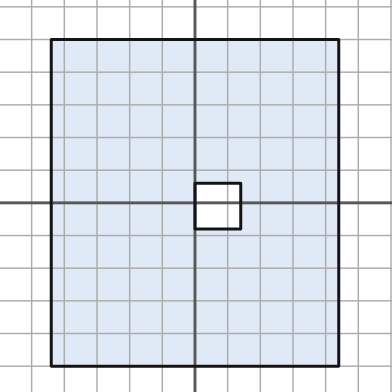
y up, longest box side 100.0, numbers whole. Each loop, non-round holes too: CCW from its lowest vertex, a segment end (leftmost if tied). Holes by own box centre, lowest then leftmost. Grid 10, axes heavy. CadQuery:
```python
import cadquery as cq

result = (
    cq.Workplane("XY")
    .moveTo(-44.0, -50.0)
    .lineTo(44.0, -50.0)
    .lineTo(44.0, 50.0)
    .lineTo(-44.0, 50.0)
    .close()
    .moveTo(0.0, -8.0)
    .lineTo(14.0, -8.0)
    .lineTo(14.0, 6.0)
    .lineTo(0.0, 6.0)
    .close()
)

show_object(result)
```